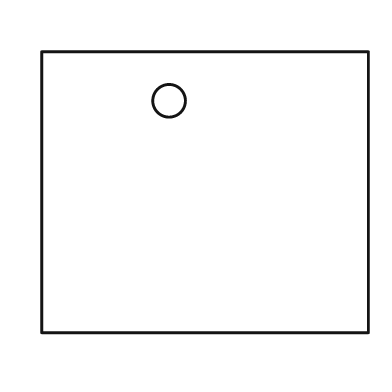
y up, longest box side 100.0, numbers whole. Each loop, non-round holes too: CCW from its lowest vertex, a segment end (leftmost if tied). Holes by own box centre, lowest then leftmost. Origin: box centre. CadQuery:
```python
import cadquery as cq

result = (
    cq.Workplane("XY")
    .moveTo(-50.0, -43.0)
    .lineTo(50.0, -43.0)
    .lineTo(50.0, 43.0)
    .lineTo(-50.0, 43.0)
    .close()
    .moveTo(-11.0, 28.0)
    .circle(5.0)
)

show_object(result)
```